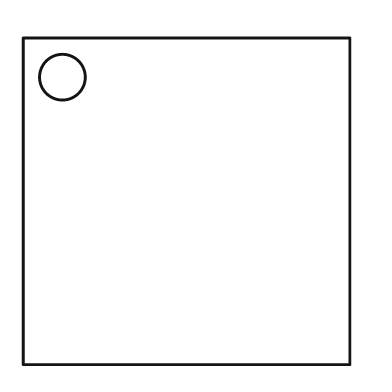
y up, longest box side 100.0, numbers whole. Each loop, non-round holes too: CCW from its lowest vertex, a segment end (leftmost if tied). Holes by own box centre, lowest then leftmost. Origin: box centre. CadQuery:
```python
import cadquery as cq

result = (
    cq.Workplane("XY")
    .moveTo(-50.0, -50.0)
    .lineTo(50.0, -50.0)
    .lineTo(50.0, 50.0)
    .lineTo(-50.0, 50.0)
    .close()
    .moveTo(-38.0, 38.0)
    .circle(7.0)
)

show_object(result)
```